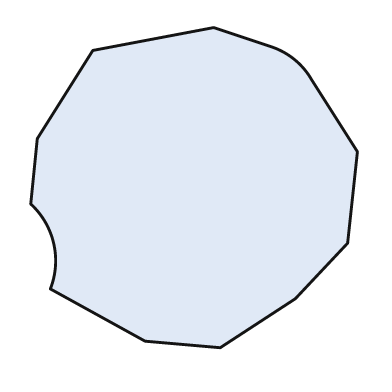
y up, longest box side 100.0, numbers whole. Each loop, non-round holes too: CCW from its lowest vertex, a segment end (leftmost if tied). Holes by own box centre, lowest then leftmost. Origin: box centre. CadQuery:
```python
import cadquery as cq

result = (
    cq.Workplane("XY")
    .moveTo(8.0, -49.0)
    .lineTo(31.0, -34.0)
    .lineTo(47.0, -17.0)
    .lineTo(50.0, 11.0)
    .lineTo(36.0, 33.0)
    .threePointArc((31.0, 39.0), (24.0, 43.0))
    .lineTo(6.0, 49.0)
    .lineTo(-31.0, 42.0)
    .lineTo(-48.0, 15.0)
    .lineTo(-50.0, -5.0)
    .threePointArc((-43.0, -17.0), (-44.0, -31.0))
    .lineTo(-15.0, -47.0)
    .close()
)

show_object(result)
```